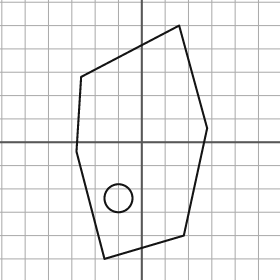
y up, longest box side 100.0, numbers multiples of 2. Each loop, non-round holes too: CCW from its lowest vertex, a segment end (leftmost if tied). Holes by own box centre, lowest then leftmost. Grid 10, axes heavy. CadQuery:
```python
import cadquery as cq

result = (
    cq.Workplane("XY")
    .moveTo(-16.0, -50.0)
    .lineTo(18.0, -40.0)
    .lineTo(28.0, 6.0)
    .lineTo(16.0, 50.0)
    .lineTo(-26.0, 28.0)
    .lineTo(-28.0, -4.0)
    .close()
    .moveTo(-10.0, -24.0)
    .circle(6.0)
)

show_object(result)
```